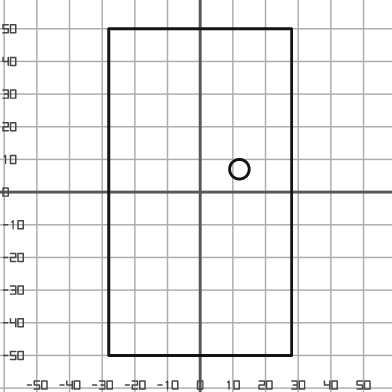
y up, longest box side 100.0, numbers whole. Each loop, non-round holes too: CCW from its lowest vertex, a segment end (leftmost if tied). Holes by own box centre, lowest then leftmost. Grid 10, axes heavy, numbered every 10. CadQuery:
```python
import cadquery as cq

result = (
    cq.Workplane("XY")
    .moveTo(-28.0, -50.0)
    .lineTo(28.0, -50.0)
    .lineTo(28.0, 50.0)
    .lineTo(-28.0, 50.0)
    .close()
    .moveTo(12.0, 7.0)
    .circle(3.0)
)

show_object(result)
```